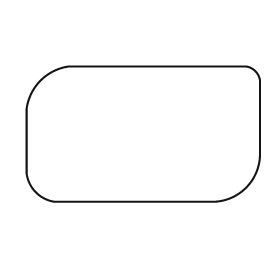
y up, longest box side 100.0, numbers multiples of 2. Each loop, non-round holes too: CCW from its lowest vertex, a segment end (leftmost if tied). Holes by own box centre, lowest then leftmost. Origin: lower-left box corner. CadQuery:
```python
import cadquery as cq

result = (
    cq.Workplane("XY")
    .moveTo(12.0, 0.0)
    .lineTo(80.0, 0.0)
    .threePointArc((94.0, 6.0), (100.0, 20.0))
    .lineTo(100.0, 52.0)
    .threePointArc((98.0, 56.0), (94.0, 58.0))
    .lineTo(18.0, 58.0)
    .threePointArc((6.0, 52.0), (0.0, 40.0))
    .lineTo(0.0, 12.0)
    .threePointArc((4.0, 4.0), (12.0, 0.0))
    .close()
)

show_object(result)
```